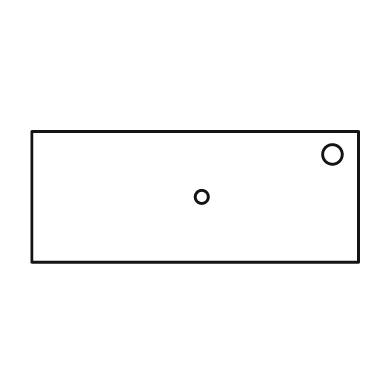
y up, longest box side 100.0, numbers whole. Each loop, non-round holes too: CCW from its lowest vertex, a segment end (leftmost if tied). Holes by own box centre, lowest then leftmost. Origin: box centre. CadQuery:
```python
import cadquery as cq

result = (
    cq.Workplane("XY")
    .moveTo(-50.0, -20.0)
    .lineTo(50.0, -20.0)
    .lineTo(50.0, 20.0)
    .lineTo(-50.0, 20.0)
    .close()
    .moveTo(2.0, 0.0)
    .circle(2.0)
    .moveTo(42.0, 13.0)
    .circle(3.0)
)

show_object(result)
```